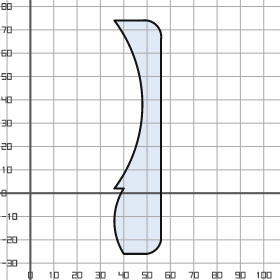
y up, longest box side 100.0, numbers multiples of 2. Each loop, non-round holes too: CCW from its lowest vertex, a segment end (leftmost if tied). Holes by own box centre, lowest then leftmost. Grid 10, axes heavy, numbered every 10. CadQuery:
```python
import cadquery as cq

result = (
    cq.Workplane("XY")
    .moveTo(40.0, -26.0)
    .lineTo(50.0, -26.0)
    .threePointArc((54.0, -24.0), (56.0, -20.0))
    .lineTo(56.0, 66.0)
    .threePointArc((54.0, 72.0), (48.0, 74.0))
    .lineTo(36.0, 74.0)
    .threePointArc((48.0, 38.0), (36.0, 2.0))
    .lineTo(40.0, 2.0)
    .threePointArc((36.0, -12.0), (40.0, -26.0))
    .close()
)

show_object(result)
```